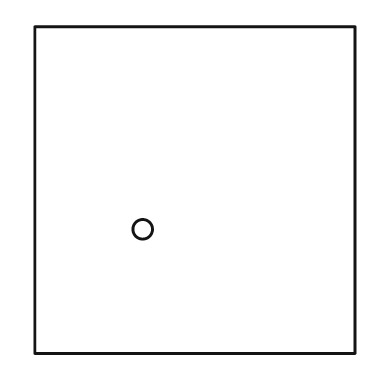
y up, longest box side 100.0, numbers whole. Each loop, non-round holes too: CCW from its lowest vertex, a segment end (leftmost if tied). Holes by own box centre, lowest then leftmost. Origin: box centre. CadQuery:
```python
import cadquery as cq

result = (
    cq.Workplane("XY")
    .moveTo(-49.0, -50.0)
    .lineTo(49.0, -50.0)
    .lineTo(49.0, 50.0)
    .lineTo(-49.0, 50.0)
    .close()
    .moveTo(-16.0, -12.0)
    .circle(3.0)
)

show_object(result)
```